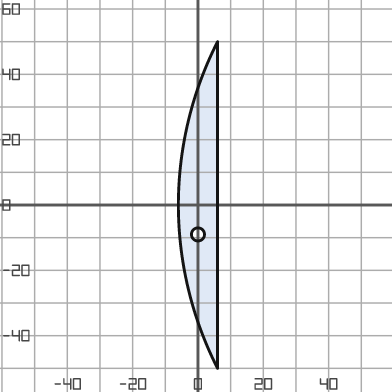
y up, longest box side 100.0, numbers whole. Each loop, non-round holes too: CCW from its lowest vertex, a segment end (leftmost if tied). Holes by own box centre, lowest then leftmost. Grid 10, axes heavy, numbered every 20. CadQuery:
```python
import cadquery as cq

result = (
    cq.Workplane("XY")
    .moveTo(6.0, -50.0)
    .lineTo(6.0, 50.0)
    .threePointArc((-6.0, 0.0), (6.0, -50.0))
    .close()
    .moveTo(0.0, -9.0)
    .circle(2.0)
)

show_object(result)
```